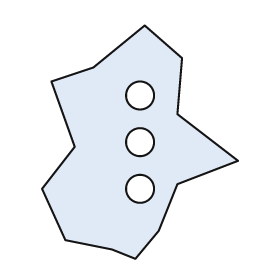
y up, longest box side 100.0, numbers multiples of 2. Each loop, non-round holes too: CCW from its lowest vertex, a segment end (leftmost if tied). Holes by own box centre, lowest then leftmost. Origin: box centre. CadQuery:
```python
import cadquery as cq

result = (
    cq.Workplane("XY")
    .moveTo(-2.0, -50.0)
    .lineTo(8.0, -38.0)
    .lineTo(16.0, -18.0)
    .lineTo(42.0, -8.0)
    .lineTo(16.0, 12.0)
    .lineTo(18.0, 36.0)
    .lineTo(2.0, 50.0)
    .lineTo(-20.0, 32.0)
    .lineTo(-38.0, 26.0)
    .lineTo(-28.0, -2.0)
    .lineTo(-42.0, -20.0)
    .lineTo(-32.0, -42.0)
    .lineTo(-12.0, -46.0)
    .close()
    .moveTo(0.0, -20.0)
    .circle(6.0)
    .moveTo(0.0, 0.0)
    .circle(6.0)
    .moveTo(0.0, 20.0)
    .circle(6.0)
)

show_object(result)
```